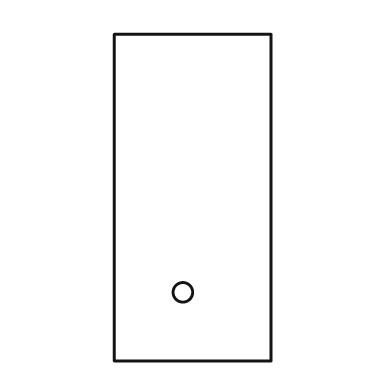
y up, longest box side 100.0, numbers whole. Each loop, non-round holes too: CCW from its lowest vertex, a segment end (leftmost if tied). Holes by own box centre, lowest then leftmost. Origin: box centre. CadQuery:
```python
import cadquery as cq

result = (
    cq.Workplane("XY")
    .moveTo(-24.0, -50.0)
    .lineTo(24.0, -50.0)
    .lineTo(24.0, 50.0)
    .lineTo(-24.0, 50.0)
    .close()
    .moveTo(-3.0, -29.0)
    .circle(3.0)
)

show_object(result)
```